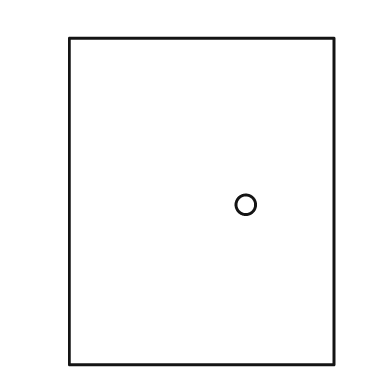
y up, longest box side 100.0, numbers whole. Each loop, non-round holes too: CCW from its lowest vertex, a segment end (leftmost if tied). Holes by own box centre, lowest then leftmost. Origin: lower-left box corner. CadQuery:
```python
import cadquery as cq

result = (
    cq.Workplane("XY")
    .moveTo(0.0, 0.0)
    .lineTo(81.0, 0.0)
    .lineTo(81.0, 100.0)
    .lineTo(0.0, 100.0)
    .close()
    .moveTo(54.0, 49.0)
    .circle(3.0)
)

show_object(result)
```